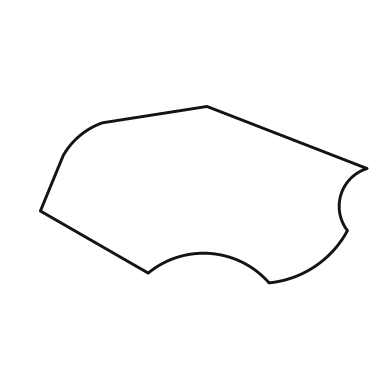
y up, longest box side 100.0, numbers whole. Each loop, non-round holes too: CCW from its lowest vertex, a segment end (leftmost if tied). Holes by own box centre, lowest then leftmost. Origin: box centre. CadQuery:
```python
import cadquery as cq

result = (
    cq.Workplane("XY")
    .moveTo(20.0, -27.0)
    .threePointArc((34.0, -22.0), (44.0, -11.0))
    .threePointArc((42.0, 0.0), (50.0, 8.0))
    .lineTo(1.0, 27.0)
    .lineTo(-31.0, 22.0)
    .threePointArc((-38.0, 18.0), (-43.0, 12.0))
    .lineTo(-50.0, -5.0)
    .lineTo(-17.0, -24.0)
    .threePointArc((2.0, -18.0), (20.0, -27.0))
    .close()
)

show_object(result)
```